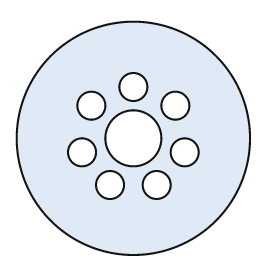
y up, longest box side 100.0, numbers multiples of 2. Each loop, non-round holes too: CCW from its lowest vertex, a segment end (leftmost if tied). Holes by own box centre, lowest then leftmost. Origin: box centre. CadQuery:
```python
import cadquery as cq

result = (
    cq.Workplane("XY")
    .moveTo(0.0, 0.0)
    .circle(50.0)
    .moveTo(-10.0, -20.0)
    .circle(6.0)
    .moveTo(10.0, -20.0)
    .circle(6.0)
    .moveTo(-22.0, -6.0)
    .circle(6.0)
    .moveTo(22.0, -6.0)
    .circle(6.0)
    .moveTo(0.0, 0.0)
    .circle(12.0)
    .moveTo(-18.0, 14.0)
    .circle(6.0)
    .moveTo(18.0, 14.0)
    .circle(6.0)
    .moveTo(0.0, 22.0)
    .circle(6.0)
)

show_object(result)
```